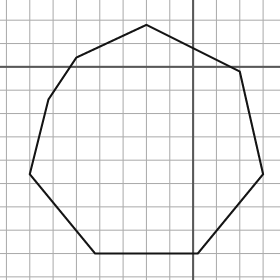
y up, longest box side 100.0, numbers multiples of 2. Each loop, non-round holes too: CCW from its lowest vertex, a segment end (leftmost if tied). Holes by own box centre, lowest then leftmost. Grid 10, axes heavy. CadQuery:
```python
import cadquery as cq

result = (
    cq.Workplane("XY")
    .moveTo(-42.0, -80.0)
    .lineTo(2.0, -80.0)
    .lineTo(30.0, -46.0)
    .lineTo(20.0, -2.0)
    .lineTo(-20.0, 18.0)
    .lineTo(-50.0, 4.0)
    .lineTo(-62.0, -14.0)
    .lineTo(-70.0, -46.0)
    .close()
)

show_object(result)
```